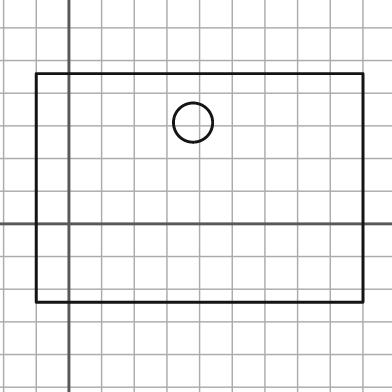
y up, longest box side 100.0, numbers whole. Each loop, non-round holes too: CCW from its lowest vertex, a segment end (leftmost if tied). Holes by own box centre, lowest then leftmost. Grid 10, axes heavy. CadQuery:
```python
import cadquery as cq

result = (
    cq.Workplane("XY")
    .moveTo(-10.0, -24.0)
    .lineTo(90.0, -24.0)
    .lineTo(90.0, 46.0)
    .lineTo(-10.0, 46.0)
    .close()
    .moveTo(38.0, 31.0)
    .circle(6.0)
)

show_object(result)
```